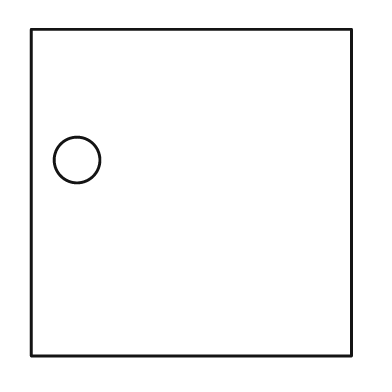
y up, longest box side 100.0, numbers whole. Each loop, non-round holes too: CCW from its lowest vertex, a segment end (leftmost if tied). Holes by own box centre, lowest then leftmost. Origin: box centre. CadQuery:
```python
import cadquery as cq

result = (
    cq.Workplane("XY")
    .moveTo(-49.0, -50.0)
    .lineTo(49.0, -50.0)
    .lineTo(49.0, 50.0)
    .lineTo(-49.0, 50.0)
    .close()
    .moveTo(-35.0, 10.0)
    .circle(7.0)
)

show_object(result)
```